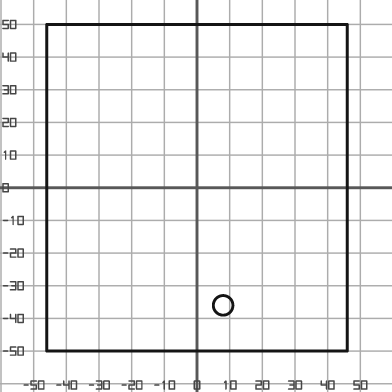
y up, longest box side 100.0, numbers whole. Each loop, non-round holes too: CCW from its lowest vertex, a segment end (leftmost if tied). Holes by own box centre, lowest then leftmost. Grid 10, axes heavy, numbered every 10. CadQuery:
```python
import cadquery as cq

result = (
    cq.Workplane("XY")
    .moveTo(-46.0, -50.0)
    .lineTo(46.0, -50.0)
    .lineTo(46.0, 50.0)
    .lineTo(-46.0, 50.0)
    .close()
    .moveTo(8.0, -36.0)
    .circle(3.0)
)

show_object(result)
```